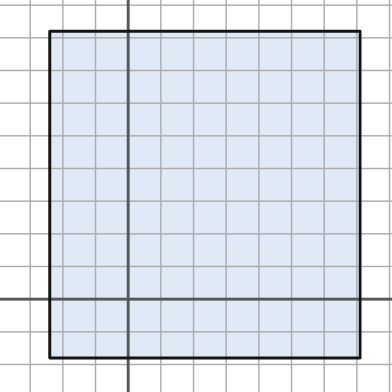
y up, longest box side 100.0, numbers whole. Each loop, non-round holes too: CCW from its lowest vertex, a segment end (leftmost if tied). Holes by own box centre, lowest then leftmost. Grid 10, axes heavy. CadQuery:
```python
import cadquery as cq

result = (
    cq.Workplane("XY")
    .moveTo(-24.0, -18.0)
    .lineTo(71.0, -18.0)
    .lineTo(71.0, 82.0)
    .lineTo(-24.0, 82.0)
    .close()
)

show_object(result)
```